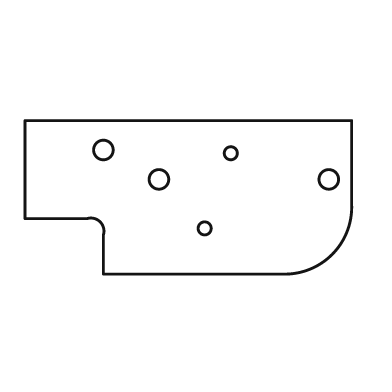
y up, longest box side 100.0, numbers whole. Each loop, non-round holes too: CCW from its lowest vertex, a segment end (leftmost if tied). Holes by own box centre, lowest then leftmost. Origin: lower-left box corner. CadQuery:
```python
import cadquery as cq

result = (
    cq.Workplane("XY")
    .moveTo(24.0, 0.0)
    .lineTo(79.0, 0.0)
    .threePointArc((94.0, 6.0), (100.0, 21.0))
    .lineTo(100.0, 47.0)
    .lineTo(0.0, 47.0)
    .lineTo(0.0, 17.0)
    .lineTo(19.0, 17.0)
    .threePointArc((23.0, 16.0), (24.0, 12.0))
    .close()
    .moveTo(55.0, 14.0)
    .circle(2.0)
    .moveTo(41.0, 29.0)
    .circle(3.0)
    .moveTo(93.0, 29.0)
    .circle(3.0)
    .moveTo(63.0, 37.0)
    .circle(2.0)
    .moveTo(24.0, 38.0)
    .circle(3.0)
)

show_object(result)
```